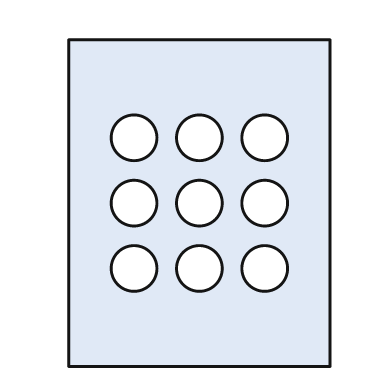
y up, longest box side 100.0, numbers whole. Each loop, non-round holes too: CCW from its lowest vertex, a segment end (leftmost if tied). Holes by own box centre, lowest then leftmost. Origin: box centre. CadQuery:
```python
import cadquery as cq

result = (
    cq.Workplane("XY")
    .moveTo(-40.0, -50.0)
    .lineTo(40.0, -50.0)
    .lineTo(40.0, 50.0)
    .lineTo(-40.0, 50.0)
    .close()
    .moveTo(-20.0, -20.0)
    .circle(7.0)
    .moveTo(0.0, -20.0)
    .circle(7.0)
    .moveTo(20.0, -20.0)
    .circle(7.0)
    .moveTo(-20.0, 0.0)
    .circle(7.0)
    .moveTo(0.0, 0.0)
    .circle(7.0)
    .moveTo(20.0, 0.0)
    .circle(7.0)
    .moveTo(-20.0, 20.0)
    .circle(7.0)
    .moveTo(0.0, 20.0)
    .circle(7.0)
    .moveTo(20.0, 20.0)
    .circle(7.0)
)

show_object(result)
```